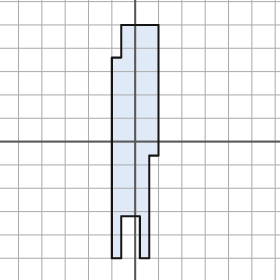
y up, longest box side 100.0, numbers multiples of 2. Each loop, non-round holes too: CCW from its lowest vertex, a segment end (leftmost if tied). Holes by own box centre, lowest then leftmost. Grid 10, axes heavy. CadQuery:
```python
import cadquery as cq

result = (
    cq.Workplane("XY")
    .moveTo(-10.0, -50.0)
    .lineTo(-6.0, -50.0)
    .lineTo(-6.0, -32.0)
    .lineTo(2.0, -32.0)
    .lineTo(2.0, -50.0)
    .lineTo(6.0, -50.0)
    .lineTo(6.0, -6.0)
    .lineTo(10.0, -6.0)
    .lineTo(10.0, 50.0)
    .lineTo(-6.0, 50.0)
    .lineTo(-6.0, 36.0)
    .lineTo(-10.0, 36.0)
    .close()
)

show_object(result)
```